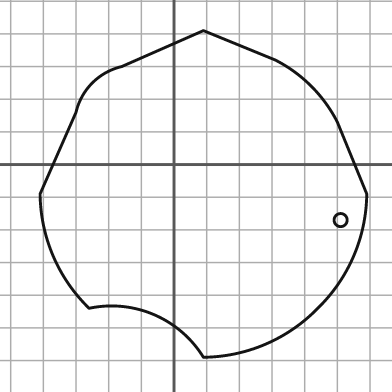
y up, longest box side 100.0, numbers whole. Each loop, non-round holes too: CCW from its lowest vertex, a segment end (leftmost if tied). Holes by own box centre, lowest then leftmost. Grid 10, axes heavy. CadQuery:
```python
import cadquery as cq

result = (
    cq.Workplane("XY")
    .moveTo(9.0, -59.0)
    .threePointArc((28.0, -55.0), (44.0, -44.0))
    .threePointArc((55.0, -28.0), (59.0, -9.0))
    .lineTo(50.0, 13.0)
    .threePointArc((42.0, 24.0), (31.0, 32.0))
    .lineTo(9.0, 41.0)
    .lineTo(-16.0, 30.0)
    .threePointArc((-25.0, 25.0), (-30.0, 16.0))
    .lineTo(-41.0, -9.0)
    .threePointArc((-37.0, -28.0), (-26.0, -44.0))
    .threePointArc((-6.0, -46.0), (9.0, -59.0))
    .close()
    .moveTo(51.0, -17.0)
    .circle(2.0)
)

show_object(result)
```